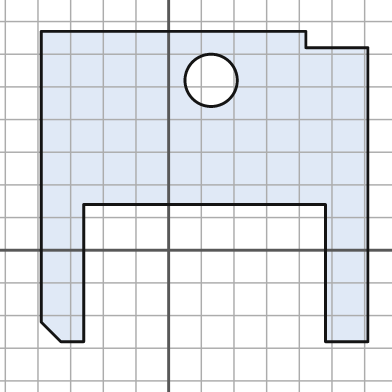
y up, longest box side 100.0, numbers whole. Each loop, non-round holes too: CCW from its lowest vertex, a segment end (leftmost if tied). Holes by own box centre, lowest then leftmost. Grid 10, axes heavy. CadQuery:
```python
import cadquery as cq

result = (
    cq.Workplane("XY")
    .moveTo(-33.0, -28.0)
    .lineTo(-26.0, -28.0)
    .lineTo(-26.0, 14.0)
    .lineTo(48.0, 14.0)
    .lineTo(48.0, -28.0)
    .lineTo(61.0, -28.0)
    .lineTo(61.0, 62.0)
    .lineTo(42.0, 62.0)
    .lineTo(42.0, 67.0)
    .lineTo(-39.0, 67.0)
    .lineTo(-39.0, -22.0)
    .close()
    .moveTo(13.0, 52.0)
    .circle(8.0)
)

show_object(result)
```